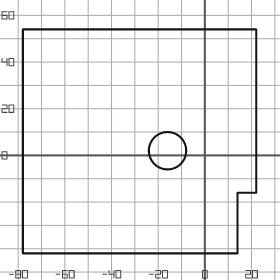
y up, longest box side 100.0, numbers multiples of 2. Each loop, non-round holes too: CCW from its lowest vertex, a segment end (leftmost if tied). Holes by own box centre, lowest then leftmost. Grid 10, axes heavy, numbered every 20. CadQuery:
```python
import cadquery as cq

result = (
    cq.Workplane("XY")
    .moveTo(-78.0, -42.0)
    .lineTo(14.0, -42.0)
    .lineTo(14.0, -16.0)
    .lineTo(22.0, -16.0)
    .lineTo(22.0, 54.0)
    .lineTo(-78.0, 54.0)
    .close()
    .moveTo(-16.0, 2.0)
    .circle(8.0)
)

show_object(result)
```